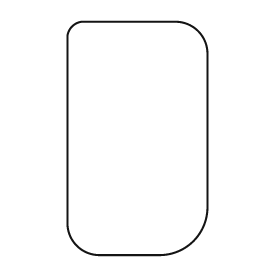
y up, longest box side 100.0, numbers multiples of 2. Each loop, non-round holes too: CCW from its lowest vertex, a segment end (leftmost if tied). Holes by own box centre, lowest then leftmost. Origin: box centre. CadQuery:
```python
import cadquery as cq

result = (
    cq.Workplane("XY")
    .moveTo(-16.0, -50.0)
    .lineTo(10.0, -50.0)
    .threePointArc((24.0, -44.0), (30.0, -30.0))
    .lineTo(30.0, 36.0)
    .threePointArc((26.0, 46.0), (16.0, 50.0))
    .lineTo(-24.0, 50.0)
    .threePointArc((-28.0, 48.0), (-30.0, 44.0))
    .lineTo(-30.0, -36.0)
    .threePointArc((-26.0, -46.0), (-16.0, -50.0))
    .close()
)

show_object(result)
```